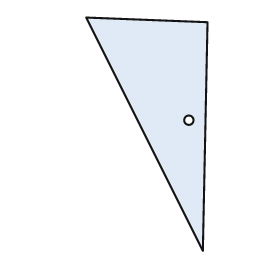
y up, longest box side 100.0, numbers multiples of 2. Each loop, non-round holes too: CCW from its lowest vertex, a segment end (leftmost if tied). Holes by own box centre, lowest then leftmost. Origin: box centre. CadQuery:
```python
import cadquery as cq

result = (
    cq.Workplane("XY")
    .moveTo(24.0, -50.0)
    .lineTo(26.0, 48.0)
    .lineTo(-26.0, 50.0)
    .close()
    .moveTo(18.0, 6.0)
    .circle(2.0)
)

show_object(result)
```